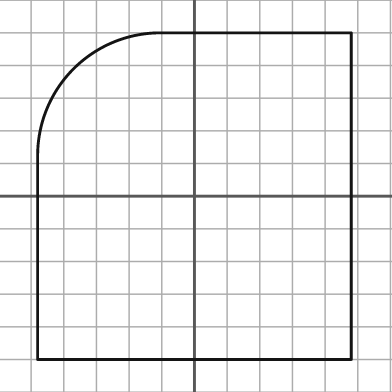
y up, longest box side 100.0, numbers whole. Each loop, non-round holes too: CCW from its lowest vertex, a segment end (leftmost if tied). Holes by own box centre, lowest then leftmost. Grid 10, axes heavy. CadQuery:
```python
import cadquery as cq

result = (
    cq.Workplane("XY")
    .moveTo(-48.0, -50.0)
    .lineTo(48.0, -50.0)
    .lineTo(48.0, 50.0)
    .lineTo(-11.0, 50.0)
    .threePointArc((-37.0, 39.0), (-48.0, 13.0))
    .close()
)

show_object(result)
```